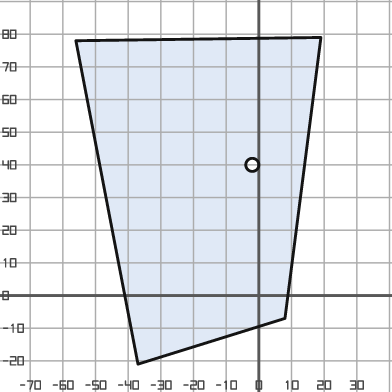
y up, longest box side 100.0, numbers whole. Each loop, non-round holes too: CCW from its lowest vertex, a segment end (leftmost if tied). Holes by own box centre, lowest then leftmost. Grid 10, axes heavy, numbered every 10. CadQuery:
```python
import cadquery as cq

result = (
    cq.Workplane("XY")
    .moveTo(-37.0, -21.0)
    .lineTo(8.0, -7.0)
    .lineTo(19.0, 79.0)
    .lineTo(-56.0, 78.0)
    .close()
    .moveTo(-2.0, 40.0)
    .circle(2.0)
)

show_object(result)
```